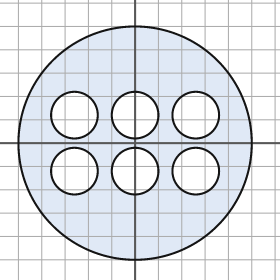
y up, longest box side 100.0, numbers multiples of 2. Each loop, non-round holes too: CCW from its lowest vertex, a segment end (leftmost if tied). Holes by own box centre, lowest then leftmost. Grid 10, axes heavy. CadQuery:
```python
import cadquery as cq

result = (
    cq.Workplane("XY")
    .moveTo(0.0, 0.0)
    .circle(50.0)
    .moveTo(-26.0, -12.0)
    .circle(10.0)
    .moveTo(0.0, -12.0)
    .circle(10.0)
    .moveTo(26.0, -12.0)
    .circle(10.0)
    .moveTo(-26.0, 12.0)
    .circle(10.0)
    .moveTo(0.0, 12.0)
    .circle(10.0)
    .moveTo(26.0, 12.0)
    .circle(10.0)
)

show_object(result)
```